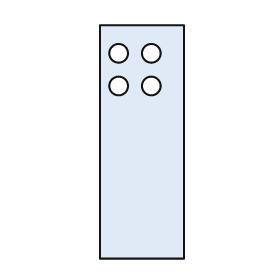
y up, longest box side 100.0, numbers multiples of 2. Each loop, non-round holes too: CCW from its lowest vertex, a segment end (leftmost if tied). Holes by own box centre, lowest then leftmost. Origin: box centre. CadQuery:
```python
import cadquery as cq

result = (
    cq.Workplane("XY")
    .moveTo(-18.0, -50.0)
    .lineTo(18.0, -50.0)
    .lineTo(18.0, 50.0)
    .lineTo(-18.0, 50.0)
    .close()
    .moveTo(-10.0, 24.0)
    .circle(4.0)
    .moveTo(4.0, 24.0)
    .circle(4.0)
    .moveTo(-10.0, 38.0)
    .circle(4.0)
    .moveTo(4.0, 38.0)
    .circle(4.0)
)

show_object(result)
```